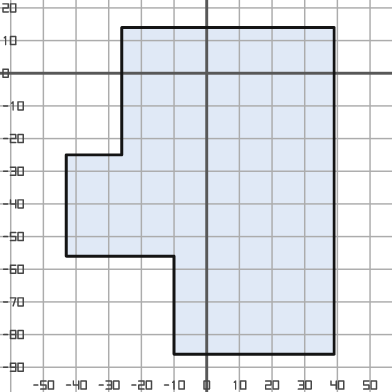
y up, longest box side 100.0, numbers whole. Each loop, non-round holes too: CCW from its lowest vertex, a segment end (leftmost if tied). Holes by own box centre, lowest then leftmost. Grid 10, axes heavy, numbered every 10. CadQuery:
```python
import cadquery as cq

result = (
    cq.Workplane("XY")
    .moveTo(-10.0, -86.0)
    .lineTo(39.0, -86.0)
    .lineTo(39.0, 14.0)
    .lineTo(-26.0, 14.0)
    .lineTo(-26.0, -25.0)
    .lineTo(-43.0, -25.0)
    .lineTo(-43.0, -56.0)
    .lineTo(-10.0, -56.0)
    .close()
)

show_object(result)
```